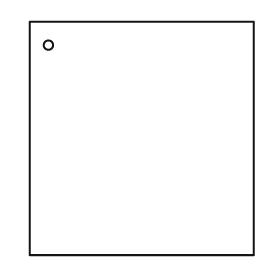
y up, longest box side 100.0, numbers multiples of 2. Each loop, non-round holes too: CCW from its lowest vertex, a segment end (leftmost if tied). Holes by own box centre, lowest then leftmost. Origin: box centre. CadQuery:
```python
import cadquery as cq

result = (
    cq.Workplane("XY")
    .moveTo(-48.0, -50.0)
    .lineTo(48.0, -50.0)
    .lineTo(48.0, 50.0)
    .lineTo(-48.0, 50.0)
    .close()
    .moveTo(-40.0, 40.0)
    .circle(2.0)
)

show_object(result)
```